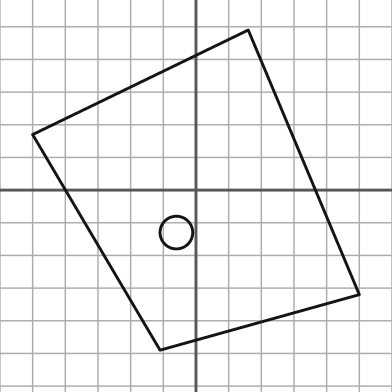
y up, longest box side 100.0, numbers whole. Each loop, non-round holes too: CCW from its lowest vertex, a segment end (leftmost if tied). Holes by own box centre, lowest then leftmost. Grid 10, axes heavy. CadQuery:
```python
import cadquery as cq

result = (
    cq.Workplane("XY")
    .moveTo(-11.0, -49.0)
    .lineTo(50.0, -32.0)
    .lineTo(16.0, 49.0)
    .lineTo(-50.0, 17.0)
    .close()
    .moveTo(-6.0, -13.0)
    .circle(5.0)
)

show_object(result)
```